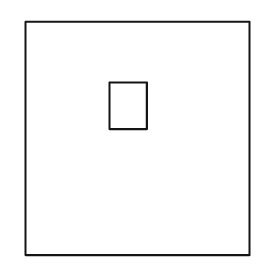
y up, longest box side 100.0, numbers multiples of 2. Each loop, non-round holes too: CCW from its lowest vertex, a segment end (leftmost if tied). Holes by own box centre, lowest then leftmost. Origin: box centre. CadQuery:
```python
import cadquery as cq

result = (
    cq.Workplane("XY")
    .moveTo(-48.0, -50.0)
    .lineTo(48.0, -50.0)
    .lineTo(48.0, 50.0)
    .lineTo(-48.0, 50.0)
    .close()
    .moveTo(-12.0, 4.0)
    .lineTo(4.0, 4.0)
    .lineTo(4.0, 24.0)
    .lineTo(-12.0, 24.0)
    .close()
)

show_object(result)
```